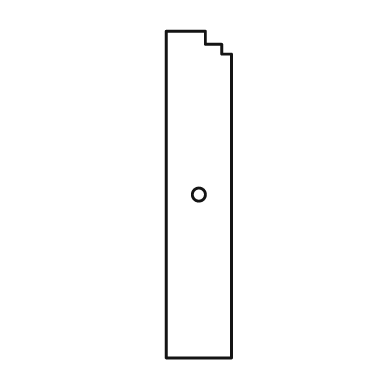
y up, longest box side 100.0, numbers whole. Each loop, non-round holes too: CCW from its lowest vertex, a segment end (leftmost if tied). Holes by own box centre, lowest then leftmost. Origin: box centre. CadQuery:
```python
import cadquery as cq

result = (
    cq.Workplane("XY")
    .moveTo(-10.0, -50.0)
    .lineTo(10.0, -50.0)
    .lineTo(10.0, 43.0)
    .lineTo(7.0, 43.0)
    .lineTo(7.0, 46.0)
    .lineTo(2.0, 46.0)
    .lineTo(2.0, 50.0)
    .lineTo(-10.0, 50.0)
    .close()
    .moveTo(0.0, 0.0)
    .circle(2.0)
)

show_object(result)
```